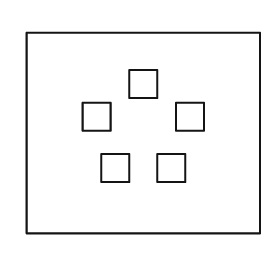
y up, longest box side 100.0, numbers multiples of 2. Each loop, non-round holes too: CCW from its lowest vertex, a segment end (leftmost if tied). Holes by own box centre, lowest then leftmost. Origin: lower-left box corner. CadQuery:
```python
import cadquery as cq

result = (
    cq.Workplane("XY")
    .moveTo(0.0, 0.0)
    .lineTo(100.0, 0.0)
    .lineTo(100.0, 86.0)
    .lineTo(0.0, 86.0)
    .close()
    .moveTo(32.0, 22.0)
    .lineTo(44.0, 22.0)
    .lineTo(44.0, 34.0)
    .lineTo(32.0, 34.0)
    .close()
    .moveTo(56.0, 22.0)
    .lineTo(68.0, 22.0)
    .lineTo(68.0, 34.0)
    .lineTo(56.0, 34.0)
    .close()
    .moveTo(24.0, 44.0)
    .lineTo(36.0, 44.0)
    .lineTo(36.0, 56.0)
    .lineTo(24.0, 56.0)
    .close()
    .moveTo(64.0, 44.0)
    .lineTo(76.0, 44.0)
    .lineTo(76.0, 56.0)
    .lineTo(64.0, 56.0)
    .close()
    .moveTo(44.0, 58.0)
    .lineTo(56.0, 58.0)
    .lineTo(56.0, 70.0)
    .lineTo(44.0, 70.0)
    .close()
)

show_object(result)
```